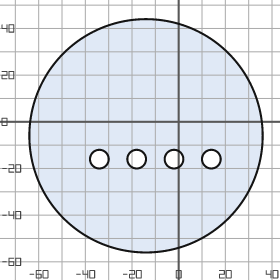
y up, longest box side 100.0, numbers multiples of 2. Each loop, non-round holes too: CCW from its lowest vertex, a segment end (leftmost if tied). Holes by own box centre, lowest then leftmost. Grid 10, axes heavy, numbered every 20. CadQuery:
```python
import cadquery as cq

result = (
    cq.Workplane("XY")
    .moveTo(-14.0, -6.0)
    .circle(50.0)
    .moveTo(-34.0, -16.0)
    .circle(4.0)
    .moveTo(-18.0, -16.0)
    .circle(4.0)
    .moveTo(-2.0, -16.0)
    .circle(4.0)
    .moveTo(14.0, -16.0)
    .circle(4.0)
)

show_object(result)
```